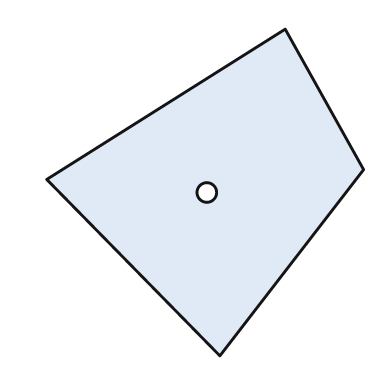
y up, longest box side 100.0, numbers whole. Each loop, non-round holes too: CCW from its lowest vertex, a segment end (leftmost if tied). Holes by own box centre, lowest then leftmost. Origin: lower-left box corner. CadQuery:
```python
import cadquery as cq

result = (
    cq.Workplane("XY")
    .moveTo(53.0, 0.0)
    .lineTo(97.0, 57.0)
    .lineTo(73.0, 100.0)
    .lineTo(0.0, 54.0)
    .close()
    .moveTo(49.0, 50.0)
    .circle(3.0)
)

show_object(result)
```